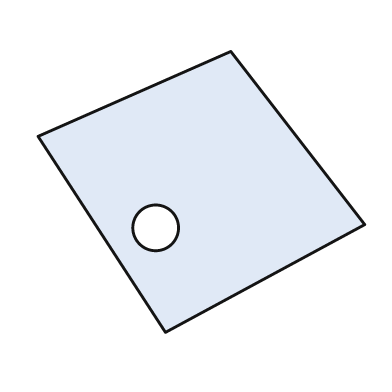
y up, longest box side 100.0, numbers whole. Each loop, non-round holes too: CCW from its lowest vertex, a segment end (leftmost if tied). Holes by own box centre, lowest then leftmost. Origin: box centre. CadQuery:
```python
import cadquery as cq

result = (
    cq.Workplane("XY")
    .moveTo(-11.0, -43.0)
    .lineTo(50.0, -10.0)
    .lineTo(9.0, 43.0)
    .lineTo(-50.0, 17.0)
    .close()
    .moveTo(-14.0, -11.0)
    .circle(7.0)
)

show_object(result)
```